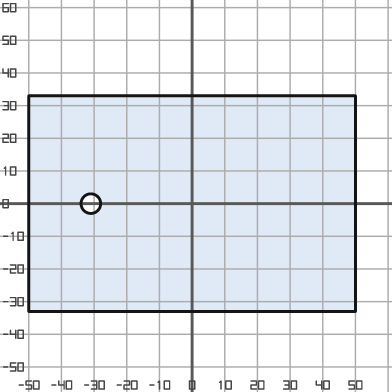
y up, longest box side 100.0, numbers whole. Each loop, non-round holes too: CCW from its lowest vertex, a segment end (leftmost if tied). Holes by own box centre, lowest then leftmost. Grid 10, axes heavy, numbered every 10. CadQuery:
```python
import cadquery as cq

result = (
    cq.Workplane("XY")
    .moveTo(-50.0, -33.0)
    .lineTo(50.0, -33.0)
    .lineTo(50.0, 33.0)
    .lineTo(-50.0, 33.0)
    .close()
    .moveTo(-31.0, 0.0)
    .circle(3.0)
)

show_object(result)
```